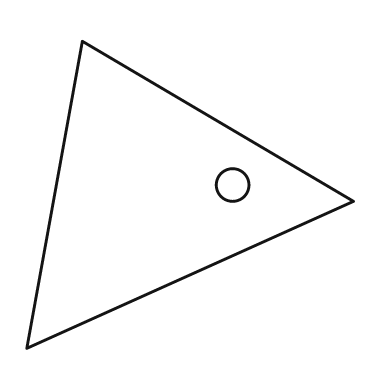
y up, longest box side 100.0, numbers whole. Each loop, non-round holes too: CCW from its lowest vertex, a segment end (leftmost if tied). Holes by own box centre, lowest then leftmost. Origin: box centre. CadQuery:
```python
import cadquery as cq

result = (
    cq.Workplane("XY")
    .moveTo(-50.0, -47.0)
    .lineTo(50.0, -2.0)
    .lineTo(-33.0, 47.0)
    .close()
    .moveTo(13.0, 3.0)
    .circle(5.0)
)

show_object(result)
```